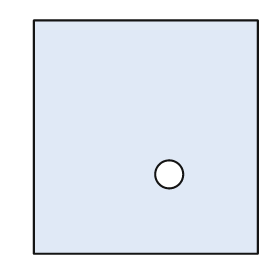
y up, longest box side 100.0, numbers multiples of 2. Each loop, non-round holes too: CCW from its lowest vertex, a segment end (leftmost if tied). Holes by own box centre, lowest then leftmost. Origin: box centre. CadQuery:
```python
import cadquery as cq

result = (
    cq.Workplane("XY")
    .moveTo(-48.0, -50.0)
    .lineTo(48.0, -50.0)
    .lineTo(48.0, 50.0)
    .lineTo(-48.0, 50.0)
    .close()
    .moveTo(10.0, -16.0)
    .circle(6.0)
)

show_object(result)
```